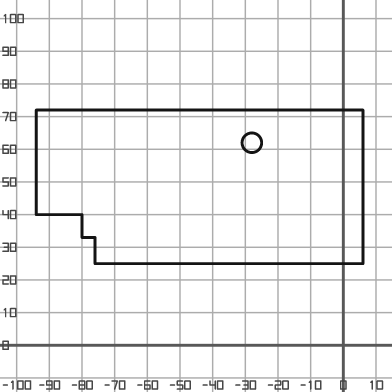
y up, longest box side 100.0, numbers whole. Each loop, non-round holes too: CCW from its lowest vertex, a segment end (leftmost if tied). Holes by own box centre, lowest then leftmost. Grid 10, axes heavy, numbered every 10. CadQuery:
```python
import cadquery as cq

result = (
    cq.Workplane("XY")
    .moveTo(-76.0, 25.0)
    .lineTo(6.0, 25.0)
    .lineTo(6.0, 72.0)
    .lineTo(-94.0, 72.0)
    .lineTo(-94.0, 40.0)
    .lineTo(-80.0, 40.0)
    .lineTo(-80.0, 33.0)
    .lineTo(-76.0, 33.0)
    .close()
    .moveTo(-28.0, 62.0)
    .circle(3.0)
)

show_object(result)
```